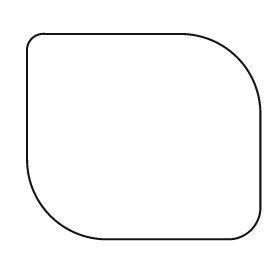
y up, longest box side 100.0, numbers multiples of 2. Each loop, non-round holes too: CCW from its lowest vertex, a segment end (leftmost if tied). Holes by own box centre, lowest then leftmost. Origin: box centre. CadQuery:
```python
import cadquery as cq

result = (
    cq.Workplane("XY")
    .moveTo(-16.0, -44.0)
    .lineTo(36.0, -44.0)
    .threePointArc((46.0, -40.0), (50.0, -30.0))
    .lineTo(50.0, 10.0)
    .threePointArc((40.0, 34.0), (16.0, 44.0))
    .lineTo(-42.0, 44.0)
    .threePointArc((-48.0, 42.0), (-50.0, 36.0))
    .lineTo(-50.0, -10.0)
    .threePointArc((-40.0, -34.0), (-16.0, -44.0))
    .close()
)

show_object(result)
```